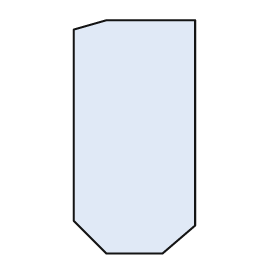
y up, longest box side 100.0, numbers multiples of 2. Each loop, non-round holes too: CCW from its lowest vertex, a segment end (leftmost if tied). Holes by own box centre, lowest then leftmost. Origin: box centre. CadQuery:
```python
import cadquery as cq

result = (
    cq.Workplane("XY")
    .moveTo(-12.0, -50.0)
    .lineTo(12.0, -50.0)
    .lineTo(26.0, -38.0)
    .lineTo(26.0, 50.0)
    .lineTo(-12.0, 50.0)
    .lineTo(-26.0, 46.0)
    .lineTo(-26.0, -36.0)
    .close()
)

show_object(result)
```